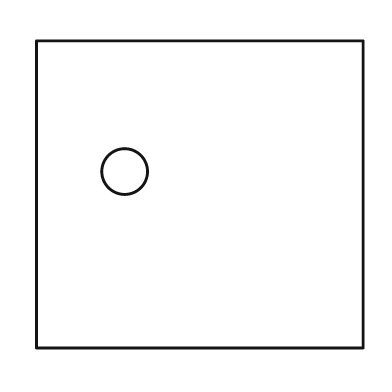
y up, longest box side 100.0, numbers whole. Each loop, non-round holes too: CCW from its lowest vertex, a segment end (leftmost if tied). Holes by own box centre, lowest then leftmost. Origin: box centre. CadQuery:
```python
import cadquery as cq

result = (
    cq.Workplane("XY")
    .moveTo(-50.0, -47.0)
    .lineTo(50.0, -47.0)
    .lineTo(50.0, 47.0)
    .lineTo(-50.0, 47.0)
    .close()
    .moveTo(-23.0, 7.0)
    .circle(7.0)
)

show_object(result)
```